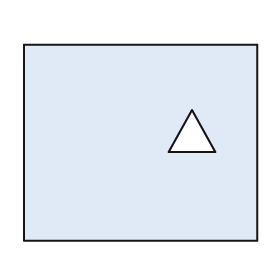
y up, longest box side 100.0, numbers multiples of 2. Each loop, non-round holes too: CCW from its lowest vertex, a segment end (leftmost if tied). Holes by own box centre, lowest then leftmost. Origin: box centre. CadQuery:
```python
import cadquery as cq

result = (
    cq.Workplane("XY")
    .moveTo(-50.0, -42.0)
    .lineTo(50.0, -42.0)
    .lineTo(50.0, 42.0)
    .lineTo(-50.0, 42.0)
    .close()
    .moveTo(12.0, -4.0)
    .lineTo(32.0, -4.0)
    .lineTo(22.0, 14.0)
    .close()
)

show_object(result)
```